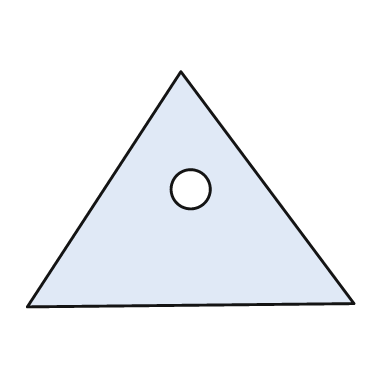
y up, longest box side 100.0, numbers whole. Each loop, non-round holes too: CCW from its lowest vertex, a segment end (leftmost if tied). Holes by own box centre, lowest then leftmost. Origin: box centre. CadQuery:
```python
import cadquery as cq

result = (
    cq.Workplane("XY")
    .moveTo(-50.0, -36.0)
    .lineTo(50.0, -35.0)
    .lineTo(-3.0, 36.0)
    .close()
    .moveTo(0.0, 0.0)
    .circle(6.0)
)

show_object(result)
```